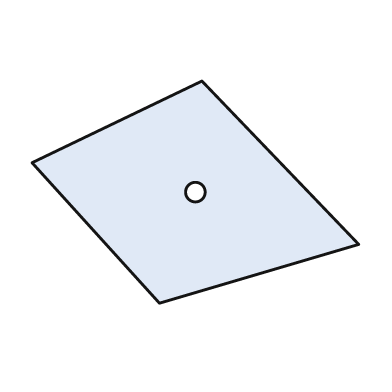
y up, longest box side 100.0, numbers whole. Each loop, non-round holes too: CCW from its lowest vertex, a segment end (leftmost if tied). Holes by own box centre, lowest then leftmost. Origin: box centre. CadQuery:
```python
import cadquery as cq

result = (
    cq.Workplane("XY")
    .moveTo(-11.0, -34.0)
    .lineTo(50.0, -16.0)
    .lineTo(2.0, 34.0)
    .lineTo(-50.0, 9.0)
    .close()
    .moveTo(0.0, 0.0)
    .circle(3.0)
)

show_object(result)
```